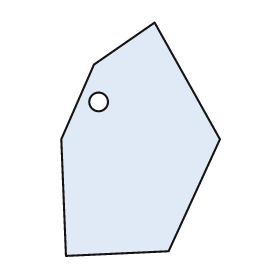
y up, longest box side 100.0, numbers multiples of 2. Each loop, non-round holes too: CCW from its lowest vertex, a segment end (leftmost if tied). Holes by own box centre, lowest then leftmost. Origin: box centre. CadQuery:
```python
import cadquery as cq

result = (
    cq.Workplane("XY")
    .moveTo(-32.0, -50.0)
    .lineTo(12.0, -48.0)
    .lineTo(34.0, 0.0)
    .lineTo(6.0, 50.0)
    .lineTo(-20.0, 32.0)
    .lineTo(-34.0, 0.0)
    .close()
    .moveTo(-18.0, 16.0)
    .circle(4.0)
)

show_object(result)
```